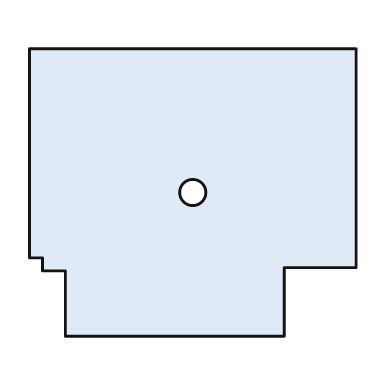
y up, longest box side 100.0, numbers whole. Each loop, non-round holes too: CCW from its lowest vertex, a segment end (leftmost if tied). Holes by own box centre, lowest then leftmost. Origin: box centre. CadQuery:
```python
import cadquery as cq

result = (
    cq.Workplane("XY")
    .moveTo(-39.0, -44.0)
    .lineTo(28.0, -44.0)
    .lineTo(28.0, -23.0)
    .lineTo(50.0, -23.0)
    .lineTo(50.0, 44.0)
    .lineTo(-50.0, 44.0)
    .lineTo(-50.0, -20.0)
    .lineTo(-46.0, -20.0)
    .lineTo(-46.0, -24.0)
    .lineTo(-39.0, -24.0)
    .close()
    .moveTo(0.0, 0.0)
    .circle(4.0)
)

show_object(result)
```